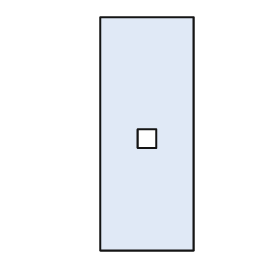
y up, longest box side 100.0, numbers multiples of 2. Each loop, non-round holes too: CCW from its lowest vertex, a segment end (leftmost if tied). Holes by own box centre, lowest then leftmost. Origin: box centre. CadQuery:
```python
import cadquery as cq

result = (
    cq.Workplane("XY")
    .moveTo(-20.0, -50.0)
    .lineTo(20.0, -50.0)
    .lineTo(20.0, 50.0)
    .lineTo(-20.0, 50.0)
    .close()
    .moveTo(-4.0, -6.0)
    .lineTo(4.0, -6.0)
    .lineTo(4.0, 2.0)
    .lineTo(-4.0, 2.0)
    .close()
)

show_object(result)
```